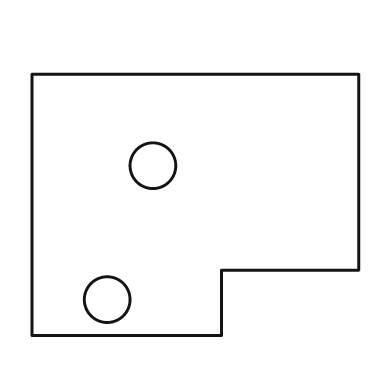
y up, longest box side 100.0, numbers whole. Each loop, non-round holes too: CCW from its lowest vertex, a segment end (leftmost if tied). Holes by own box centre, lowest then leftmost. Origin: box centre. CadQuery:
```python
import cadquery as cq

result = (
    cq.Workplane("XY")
    .moveTo(-50.0, -40.0)
    .lineTo(8.0, -40.0)
    .lineTo(8.0, -20.0)
    .lineTo(50.0, -20.0)
    .lineTo(50.0, 40.0)
    .lineTo(-50.0, 40.0)
    .close()
    .moveTo(-27.0, -29.0)
    .circle(7.0)
    .moveTo(-13.0, 12.0)
    .circle(7.0)
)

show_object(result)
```